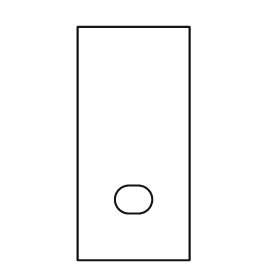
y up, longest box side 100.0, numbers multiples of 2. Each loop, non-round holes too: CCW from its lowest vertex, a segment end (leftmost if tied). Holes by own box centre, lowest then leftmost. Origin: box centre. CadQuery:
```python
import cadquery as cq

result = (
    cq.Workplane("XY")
    .moveTo(-24.0, -50.0)
    .lineTo(24.0, -50.0)
    .lineTo(24.0, 50.0)
    .lineTo(-24.0, 50.0)
    .close()
    .moveTo(-2.0, -30.0)
    .lineTo(2.0, -30.0)
    .threePointArc((8.0, -24.0), (2.0, -18.0))
    .lineTo(-2.0, -18.0)
    .threePointArc((-8.0, -24.0), (-2.0, -30.0))
    .close()
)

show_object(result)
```